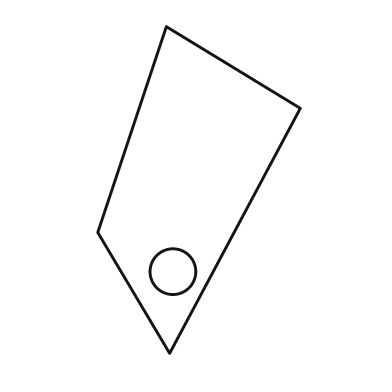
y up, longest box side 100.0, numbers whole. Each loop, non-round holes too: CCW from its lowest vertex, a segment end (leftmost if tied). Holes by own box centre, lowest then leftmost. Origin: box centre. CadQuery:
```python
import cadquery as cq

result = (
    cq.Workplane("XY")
    .moveTo(-9.0, -50.0)
    .lineTo(31.0, 25.0)
    .lineTo(-10.0, 50.0)
    .lineTo(-31.0, -13.0)
    .close()
    .moveTo(-8.0, -25.0)
    .circle(7.0)
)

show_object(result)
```